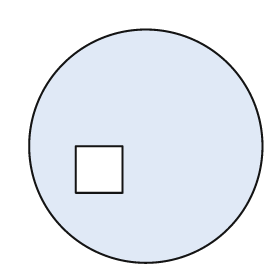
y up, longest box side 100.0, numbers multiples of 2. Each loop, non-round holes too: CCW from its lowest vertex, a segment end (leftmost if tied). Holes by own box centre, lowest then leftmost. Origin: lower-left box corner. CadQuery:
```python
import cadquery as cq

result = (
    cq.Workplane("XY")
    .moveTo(50.0, 50.0)
    .circle(50.0)
    .moveTo(20.0, 30.0)
    .lineTo(40.0, 30.0)
    .lineTo(40.0, 50.0)
    .lineTo(20.0, 50.0)
    .close()
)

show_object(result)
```